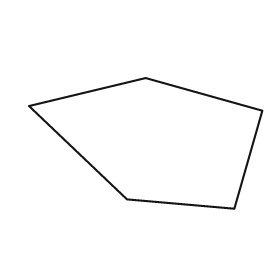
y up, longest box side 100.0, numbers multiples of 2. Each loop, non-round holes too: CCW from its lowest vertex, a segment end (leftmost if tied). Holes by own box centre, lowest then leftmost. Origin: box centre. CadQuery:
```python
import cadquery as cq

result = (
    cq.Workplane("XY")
    .moveTo(38.0, -28.0)
    .lineTo(50.0, 14.0)
    .lineTo(0.0, 28.0)
    .lineTo(-50.0, 16.0)
    .lineTo(-8.0, -24.0)
    .close()
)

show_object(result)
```